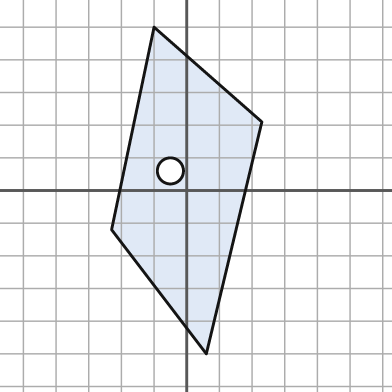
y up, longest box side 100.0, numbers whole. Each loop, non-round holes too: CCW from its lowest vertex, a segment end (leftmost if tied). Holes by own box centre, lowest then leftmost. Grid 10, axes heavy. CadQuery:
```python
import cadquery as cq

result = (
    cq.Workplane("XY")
    .moveTo(6.0, -50.0)
    .lineTo(23.0, 21.0)
    .lineTo(-10.0, 50.0)
    .lineTo(-23.0, -12.0)
    .close()
    .moveTo(-5.0, 6.0)
    .circle(4.0)
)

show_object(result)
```